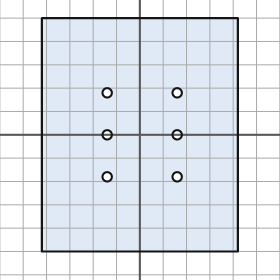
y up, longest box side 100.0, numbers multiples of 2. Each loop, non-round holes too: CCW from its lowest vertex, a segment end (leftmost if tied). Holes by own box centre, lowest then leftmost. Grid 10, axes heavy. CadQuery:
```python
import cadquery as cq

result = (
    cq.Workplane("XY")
    .moveTo(-42.0, -50.0)
    .lineTo(42.0, -50.0)
    .lineTo(42.0, 50.0)
    .lineTo(-42.0, 50.0)
    .close()
    .moveTo(-14.0, -18.0)
    .circle(2.0)
    .moveTo(16.0, -18.0)
    .circle(2.0)
    .moveTo(-14.0, 0.0)
    .circle(2.0)
    .moveTo(16.0, 0.0)
    .circle(2.0)
    .moveTo(-14.0, 18.0)
    .circle(2.0)
    .moveTo(16.0, 18.0)
    .circle(2.0)
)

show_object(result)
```